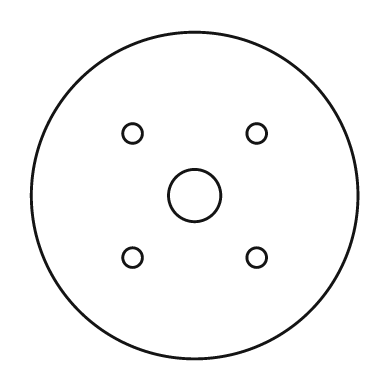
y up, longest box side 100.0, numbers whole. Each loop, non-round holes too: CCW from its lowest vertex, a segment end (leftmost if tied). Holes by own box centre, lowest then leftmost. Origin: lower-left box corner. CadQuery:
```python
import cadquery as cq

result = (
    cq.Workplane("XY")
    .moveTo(50.0, 50.0)
    .circle(50.0)
    .moveTo(31.0, 31.0)
    .circle(3.0)
    .moveTo(69.0, 31.0)
    .circle(3.0)
    .moveTo(50.0, 50.0)
    .circle(8.0)
    .moveTo(31.0, 69.0)
    .circle(3.0)
    .moveTo(69.0, 69.0)
    .circle(3.0)
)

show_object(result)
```